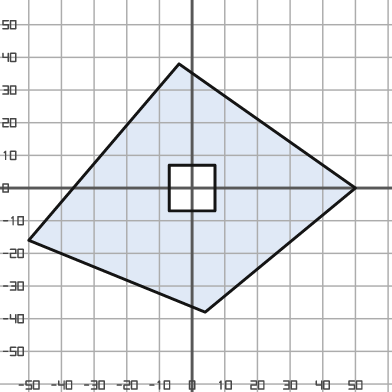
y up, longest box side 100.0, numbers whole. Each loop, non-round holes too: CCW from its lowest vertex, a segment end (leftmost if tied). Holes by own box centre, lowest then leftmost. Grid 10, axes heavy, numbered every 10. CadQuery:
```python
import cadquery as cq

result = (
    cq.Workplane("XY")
    .moveTo(4.0, -38.0)
    .lineTo(50.0, 0.0)
    .lineTo(-4.0, 38.0)
    .lineTo(-50.0, -16.0)
    .close()
    .moveTo(-7.0, -7.0)
    .lineTo(7.0, -7.0)
    .lineTo(7.0, 7.0)
    .lineTo(-7.0, 7.0)
    .close()
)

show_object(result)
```